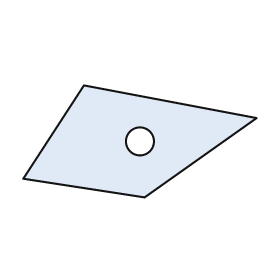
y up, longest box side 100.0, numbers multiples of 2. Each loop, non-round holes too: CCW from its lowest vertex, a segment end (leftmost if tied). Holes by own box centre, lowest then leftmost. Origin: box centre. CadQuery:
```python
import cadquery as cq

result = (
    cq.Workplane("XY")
    .moveTo(2.0, -24.0)
    .lineTo(50.0, 10.0)
    .lineTo(-24.0, 24.0)
    .lineTo(-50.0, -16.0)
    .close()
    .moveTo(0.0, 0.0)
    .circle(6.0)
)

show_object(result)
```